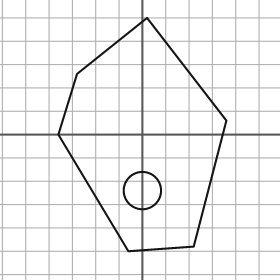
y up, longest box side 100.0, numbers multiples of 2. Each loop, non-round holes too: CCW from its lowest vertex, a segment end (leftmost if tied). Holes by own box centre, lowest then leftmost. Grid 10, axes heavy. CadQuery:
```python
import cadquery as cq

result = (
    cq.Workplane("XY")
    .moveTo(-6.0, -50.0)
    .lineTo(22.0, -48.0)
    .lineTo(36.0, 6.0)
    .lineTo(2.0, 50.0)
    .lineTo(-28.0, 26.0)
    .lineTo(-36.0, 0.0)
    .close()
    .moveTo(0.0, -24.0)
    .circle(8.0)
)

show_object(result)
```